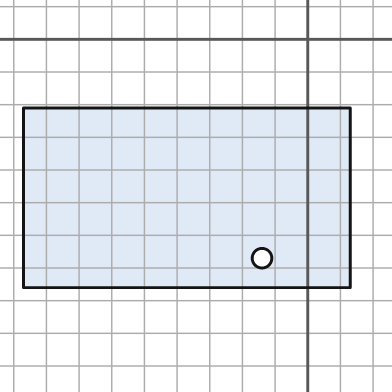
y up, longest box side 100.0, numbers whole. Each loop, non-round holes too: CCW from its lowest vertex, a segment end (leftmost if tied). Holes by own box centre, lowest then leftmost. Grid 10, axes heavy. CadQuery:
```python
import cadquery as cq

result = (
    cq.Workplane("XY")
    .moveTo(-87.0, -76.0)
    .lineTo(13.0, -76.0)
    .lineTo(13.0, -21.0)
    .lineTo(-87.0, -21.0)
    .close()
    .moveTo(-14.0, -67.0)
    .circle(3.0)
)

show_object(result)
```